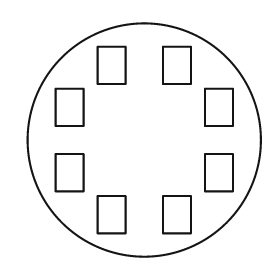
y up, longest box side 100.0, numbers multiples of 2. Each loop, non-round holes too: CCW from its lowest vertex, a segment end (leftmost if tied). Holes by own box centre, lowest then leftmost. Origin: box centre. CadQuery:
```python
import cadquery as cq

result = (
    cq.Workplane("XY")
    .moveTo(0.0, 0.0)
    .circle(50.0)
    .moveTo(-20.0, -40.0)
    .lineTo(-8.0, -40.0)
    .lineTo(-8.0, -24.0)
    .lineTo(-20.0, -24.0)
    .close()
    .moveTo(8.0, -40.0)
    .lineTo(20.0, -40.0)
    .lineTo(20.0, -24.0)
    .lineTo(8.0, -24.0)
    .close()
    .moveTo(-38.0, -22.0)
    .lineTo(-26.0, -22.0)
    .lineTo(-26.0, -6.0)
    .lineTo(-38.0, -6.0)
    .close()
    .moveTo(26.0, -22.0)
    .lineTo(38.0, -22.0)
    .lineTo(38.0, -6.0)
    .lineTo(26.0, -6.0)
    .close()
    .moveTo(-38.0, 6.0)
    .lineTo(-26.0, 6.0)
    .lineTo(-26.0, 22.0)
    .lineTo(-38.0, 22.0)
    .close()
    .moveTo(26.0, 6.0)
    .lineTo(38.0, 6.0)
    .lineTo(38.0, 22.0)
    .lineTo(26.0, 22.0)
    .close()
    .moveTo(-20.0, 24.0)
    .lineTo(-8.0, 24.0)
    .lineTo(-8.0, 40.0)
    .lineTo(-20.0, 40.0)
    .close()
    .moveTo(8.0, 24.0)
    .lineTo(20.0, 24.0)
    .lineTo(20.0, 40.0)
    .lineTo(8.0, 40.0)
    .close()
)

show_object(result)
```